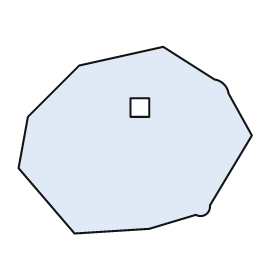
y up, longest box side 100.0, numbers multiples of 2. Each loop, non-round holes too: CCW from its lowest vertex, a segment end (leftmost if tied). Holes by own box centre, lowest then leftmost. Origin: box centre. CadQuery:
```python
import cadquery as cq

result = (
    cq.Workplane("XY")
    .moveTo(-26.0, -40.0)
    .lineTo(6.0, -38.0)
    .lineTo(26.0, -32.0)
    .threePointArc((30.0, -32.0), (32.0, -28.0))
    .lineTo(50.0, 2.0)
    .lineTo(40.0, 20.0)
    .threePointArc((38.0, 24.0), (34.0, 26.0))
    .lineTo(12.0, 40.0)
    .lineTo(-24.0, 32.0)
    .lineTo(-46.0, 10.0)
    .lineTo(-50.0, -12.0)
    .close()
    .moveTo(-2.0, 10.0)
    .lineTo(6.0, 10.0)
    .lineTo(6.0, 18.0)
    .lineTo(-2.0, 18.0)
    .close()
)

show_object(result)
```